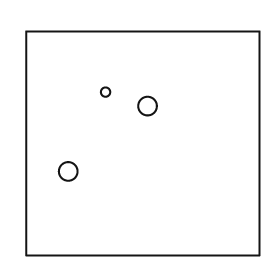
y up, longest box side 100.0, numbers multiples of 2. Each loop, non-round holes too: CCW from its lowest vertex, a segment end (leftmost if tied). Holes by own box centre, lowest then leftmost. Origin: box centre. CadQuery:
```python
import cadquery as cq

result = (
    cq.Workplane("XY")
    .moveTo(-50.0, -48.0)
    .lineTo(50.0, -48.0)
    .lineTo(50.0, 48.0)
    .lineTo(-50.0, 48.0)
    .close()
    .moveTo(-32.0, -12.0)
    .circle(4.0)
    .moveTo(2.0, 16.0)
    .circle(4.0)
    .moveTo(-16.0, 22.0)
    .circle(2.0)
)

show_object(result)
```